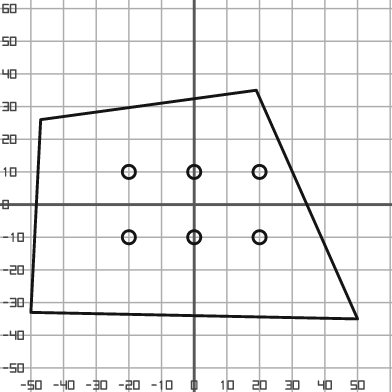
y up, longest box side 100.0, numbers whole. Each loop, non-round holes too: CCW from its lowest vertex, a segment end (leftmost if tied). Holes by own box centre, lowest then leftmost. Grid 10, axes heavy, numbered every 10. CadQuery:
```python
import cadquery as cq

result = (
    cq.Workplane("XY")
    .moveTo(50.0, -35.0)
    .lineTo(19.0, 35.0)
    .lineTo(-47.0, 26.0)
    .lineTo(-50.0, -33.0)
    .close()
    .moveTo(-20.0, -10.0)
    .circle(2.0)
    .moveTo(0.0, -10.0)
    .circle(2.0)
    .moveTo(20.0, -10.0)
    .circle(2.0)
    .moveTo(-20.0, 10.0)
    .circle(2.0)
    .moveTo(0.0, 10.0)
    .circle(2.0)
    .moveTo(20.0, 10.0)
    .circle(2.0)
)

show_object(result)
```